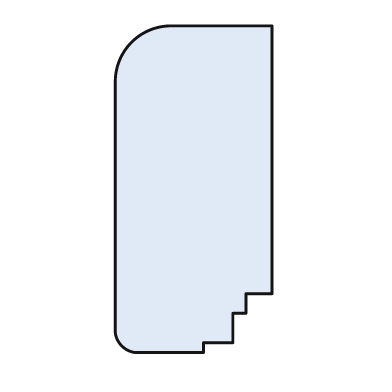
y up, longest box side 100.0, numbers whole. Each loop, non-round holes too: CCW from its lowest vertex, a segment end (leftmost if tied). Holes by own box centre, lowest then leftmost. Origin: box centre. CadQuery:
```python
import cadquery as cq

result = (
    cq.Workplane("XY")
    .moveTo(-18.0, -50.0)
    .lineTo(3.0, -50.0)
    .lineTo(3.0, -47.0)
    .lineTo(12.0, -47.0)
    .lineTo(12.0, -38.0)
    .lineTo(16.0, -38.0)
    .lineTo(16.0, -32.0)
    .lineTo(24.0, -32.0)
    .lineTo(24.0, 50.0)
    .lineTo(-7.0, 50.0)
    .threePointArc((-19.0, 45.0), (-24.0, 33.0))
    .lineTo(-24.0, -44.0)
    .threePointArc((-22.0, -48.0), (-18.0, -50.0))
    .close()
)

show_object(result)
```